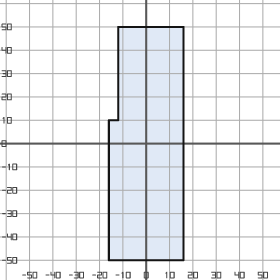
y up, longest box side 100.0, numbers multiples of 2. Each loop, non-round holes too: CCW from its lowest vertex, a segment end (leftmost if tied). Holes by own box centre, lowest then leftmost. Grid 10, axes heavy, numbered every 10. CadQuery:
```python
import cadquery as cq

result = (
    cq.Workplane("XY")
    .moveTo(-16.0, -50.0)
    .lineTo(16.0, -50.0)
    .lineTo(16.0, 50.0)
    .lineTo(-12.0, 50.0)
    .lineTo(-12.0, 10.0)
    .lineTo(-16.0, 10.0)
    .close()
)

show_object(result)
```